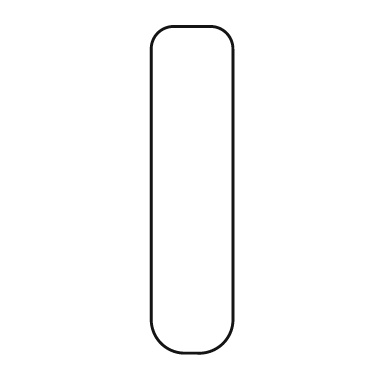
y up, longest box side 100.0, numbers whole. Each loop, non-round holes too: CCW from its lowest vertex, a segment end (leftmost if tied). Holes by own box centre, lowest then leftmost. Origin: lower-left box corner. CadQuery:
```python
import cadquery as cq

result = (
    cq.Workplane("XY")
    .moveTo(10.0, 0.0)
    .lineTo(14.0, 0.0)
    .threePointArc((22.0, 3.0), (25.0, 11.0))
    .lineTo(25.0, 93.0)
    .threePointArc((23.0, 98.0), (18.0, 100.0))
    .lineTo(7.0, 100.0)
    .threePointArc((2.0, 98.0), (0.0, 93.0))
    .lineTo(0.0, 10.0)
    .threePointArc((3.0, 3.0), (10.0, 0.0))
    .close()
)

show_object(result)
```